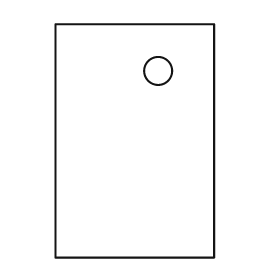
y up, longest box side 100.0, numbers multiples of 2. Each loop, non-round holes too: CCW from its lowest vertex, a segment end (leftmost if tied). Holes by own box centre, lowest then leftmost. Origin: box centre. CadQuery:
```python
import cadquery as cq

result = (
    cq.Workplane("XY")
    .moveTo(-34.0, -50.0)
    .lineTo(34.0, -50.0)
    .lineTo(34.0, 50.0)
    .lineTo(-34.0, 50.0)
    .close()
    .moveTo(10.0, 30.0)
    .circle(6.0)
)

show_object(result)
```